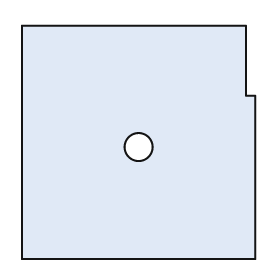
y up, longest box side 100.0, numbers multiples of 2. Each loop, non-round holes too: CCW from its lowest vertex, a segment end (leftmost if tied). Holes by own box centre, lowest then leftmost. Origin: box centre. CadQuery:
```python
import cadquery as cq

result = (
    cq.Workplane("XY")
    .moveTo(-50.0, -50.0)
    .lineTo(50.0, -50.0)
    .lineTo(50.0, 20.0)
    .lineTo(46.0, 20.0)
    .lineTo(46.0, 50.0)
    .lineTo(-50.0, 50.0)
    .close()
    .moveTo(0.0, -2.0)
    .circle(6.0)
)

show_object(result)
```